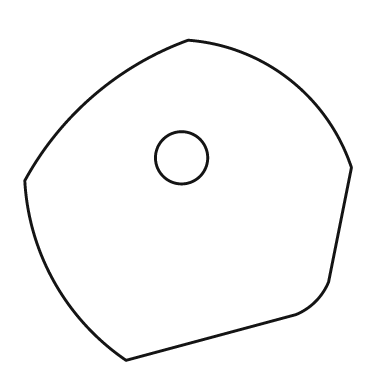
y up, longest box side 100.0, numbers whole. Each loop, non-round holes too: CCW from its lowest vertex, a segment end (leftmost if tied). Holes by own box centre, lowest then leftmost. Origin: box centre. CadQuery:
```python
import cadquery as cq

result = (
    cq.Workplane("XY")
    .moveTo(-19.0, -49.0)
    .lineTo(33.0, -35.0)
    .threePointArc((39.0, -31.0), (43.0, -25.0))
    .lineTo(50.0, 10.0)
    .threePointArc((31.0, 37.0), (0.0, 49.0))
    .threePointArc((-29.0, 32.0), (-50.0, 6.0))
    .threePointArc((-41.0, -25.0), (-19.0, -49.0))
    .close()
    .moveTo(-2.0, 13.0)
    .circle(8.0)
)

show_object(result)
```